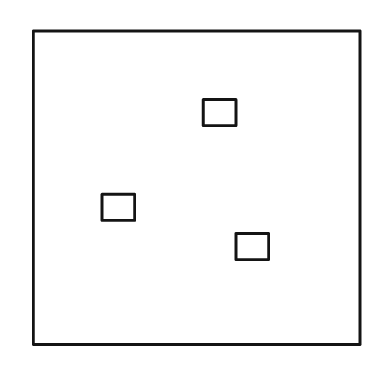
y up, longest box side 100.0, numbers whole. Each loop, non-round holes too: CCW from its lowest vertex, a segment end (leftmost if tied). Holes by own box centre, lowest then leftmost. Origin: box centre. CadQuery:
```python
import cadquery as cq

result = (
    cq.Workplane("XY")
    .moveTo(-50.0, -48.0)
    .lineTo(50.0, -48.0)
    .lineTo(50.0, 48.0)
    .lineTo(-50.0, 48.0)
    .close()
    .moveTo(12.0, -22.0)
    .lineTo(22.0, -22.0)
    .lineTo(22.0, -14.0)
    .lineTo(12.0, -14.0)
    .close()
    .moveTo(-29.0, -10.0)
    .lineTo(-19.0, -10.0)
    .lineTo(-19.0, -2.0)
    .lineTo(-29.0, -2.0)
    .close()
    .moveTo(2.0, 19.0)
    .lineTo(12.0, 19.0)
    .lineTo(12.0, 27.0)
    .lineTo(2.0, 27.0)
    .close()
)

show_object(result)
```